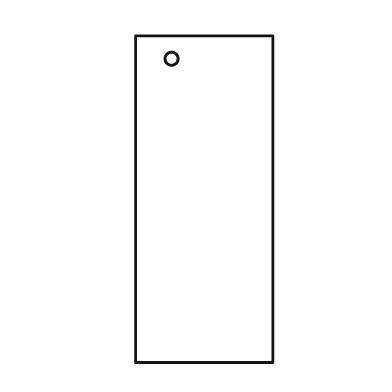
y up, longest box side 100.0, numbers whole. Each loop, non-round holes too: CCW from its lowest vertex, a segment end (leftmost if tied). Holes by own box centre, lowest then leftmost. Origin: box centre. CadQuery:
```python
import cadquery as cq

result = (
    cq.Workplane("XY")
    .moveTo(-21.0, -50.0)
    .lineTo(21.0, -50.0)
    .lineTo(21.0, 50.0)
    .lineTo(-21.0, 50.0)
    .close()
    .moveTo(-10.0, 43.0)
    .circle(2.0)
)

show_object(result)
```